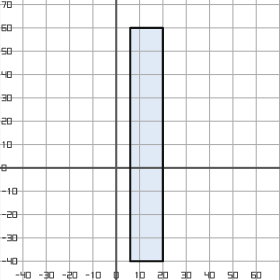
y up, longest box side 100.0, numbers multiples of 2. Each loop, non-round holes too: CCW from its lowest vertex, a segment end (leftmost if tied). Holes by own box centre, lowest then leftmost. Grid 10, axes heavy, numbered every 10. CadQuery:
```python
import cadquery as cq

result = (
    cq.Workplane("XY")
    .moveTo(6.0, -40.0)
    .lineTo(20.0, -40.0)
    .lineTo(20.0, 60.0)
    .lineTo(6.0, 60.0)
    .close()
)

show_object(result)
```